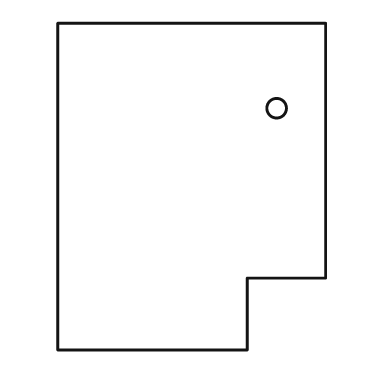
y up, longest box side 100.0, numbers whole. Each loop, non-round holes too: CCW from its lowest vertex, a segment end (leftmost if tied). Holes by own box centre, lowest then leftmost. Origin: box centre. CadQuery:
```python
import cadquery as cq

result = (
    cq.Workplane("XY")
    .moveTo(-41.0, -50.0)
    .lineTo(17.0, -50.0)
    .lineTo(17.0, -28.0)
    .lineTo(41.0, -28.0)
    .lineTo(41.0, 50.0)
    .lineTo(-41.0, 50.0)
    .close()
    .moveTo(26.0, 24.0)
    .circle(3.0)
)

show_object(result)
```